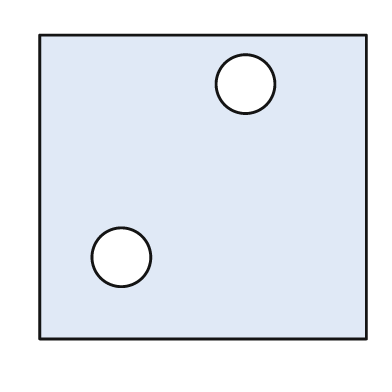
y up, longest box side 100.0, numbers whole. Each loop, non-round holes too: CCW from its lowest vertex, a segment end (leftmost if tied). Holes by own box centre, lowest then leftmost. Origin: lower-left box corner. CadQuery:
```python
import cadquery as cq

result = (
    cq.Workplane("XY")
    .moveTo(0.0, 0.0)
    .lineTo(100.0, 0.0)
    .lineTo(100.0, 93.0)
    .lineTo(0.0, 93.0)
    .close()
    .moveTo(25.0, 25.0)
    .circle(9.0)
    .moveTo(63.0, 78.0)
    .circle(9.0)
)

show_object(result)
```